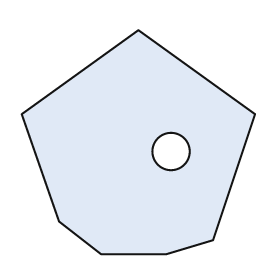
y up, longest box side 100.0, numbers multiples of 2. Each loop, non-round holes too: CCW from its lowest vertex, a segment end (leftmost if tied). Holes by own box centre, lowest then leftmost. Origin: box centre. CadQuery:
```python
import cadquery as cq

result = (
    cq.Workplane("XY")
    .moveTo(-16.0, -48.0)
    .lineTo(12.0, -48.0)
    .lineTo(32.0, -42.0)
    .lineTo(50.0, 12.0)
    .lineTo(0.0, 48.0)
    .lineTo(-50.0, 12.0)
    .lineTo(-34.0, -34.0)
    .close()
    .moveTo(14.0, -4.0)
    .circle(8.0)
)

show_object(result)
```